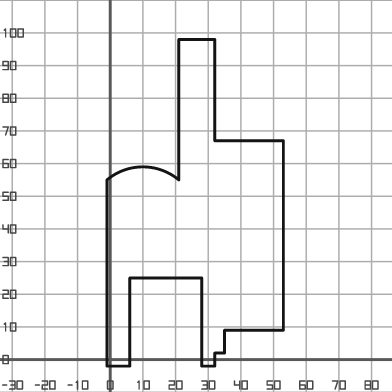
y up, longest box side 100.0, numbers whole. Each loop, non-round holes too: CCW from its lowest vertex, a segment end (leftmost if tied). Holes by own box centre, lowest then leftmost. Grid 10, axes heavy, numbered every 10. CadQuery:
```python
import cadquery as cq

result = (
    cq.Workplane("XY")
    .moveTo(-1.0, -2.0)
    .lineTo(6.0, -2.0)
    .lineTo(6.0, 25.0)
    .lineTo(28.0, 25.0)
    .lineTo(28.0, -2.0)
    .lineTo(32.0, -2.0)
    .lineTo(32.0, 2.0)
    .lineTo(35.0, 2.0)
    .lineTo(35.0, 9.0)
    .lineTo(53.0, 9.0)
    .lineTo(53.0, 67.0)
    .lineTo(32.0, 67.0)
    .lineTo(32.0, 98.0)
    .lineTo(21.0, 98.0)
    .lineTo(21.0, 55.0)
    .threePointArc((10.0, 59.0), (-1.0, 55.0))
    .close()
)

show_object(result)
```